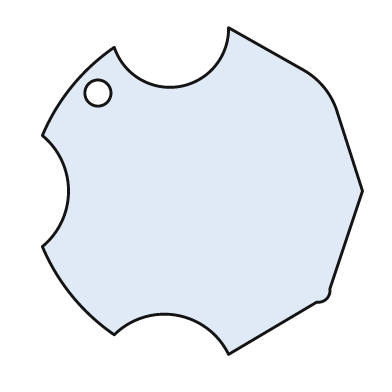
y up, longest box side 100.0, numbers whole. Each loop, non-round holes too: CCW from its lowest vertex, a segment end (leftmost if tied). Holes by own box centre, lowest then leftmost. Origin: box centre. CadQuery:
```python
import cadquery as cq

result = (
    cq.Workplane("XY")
    .moveTo(8.0, -50.0)
    .lineTo(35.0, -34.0)
    .threePointArc((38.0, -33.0), (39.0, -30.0))
    .lineTo(49.0, 0.0)
    .lineTo(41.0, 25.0)
    .threePointArc((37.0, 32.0), (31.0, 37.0))
    .lineTo(8.0, 50.0)
    .threePointArc((-7.0, 32.0), (-27.0, 44.0))
    .threePointArc((-40.0, 32.0), (-49.0, 17.0))
    .threePointArc((-41.0, 0.0), (-49.0, -17.0))
    .threePointArc((-40.0, -32.0), (-27.0, -44.0))
    .threePointArc((-8.0, -38.0), (8.0, -50.0))
    .close()
    .moveTo(-32.0, 30.0)
    .circle(4.0)
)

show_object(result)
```